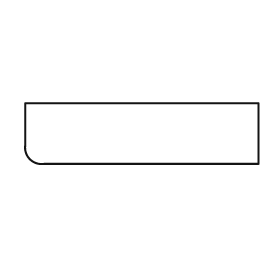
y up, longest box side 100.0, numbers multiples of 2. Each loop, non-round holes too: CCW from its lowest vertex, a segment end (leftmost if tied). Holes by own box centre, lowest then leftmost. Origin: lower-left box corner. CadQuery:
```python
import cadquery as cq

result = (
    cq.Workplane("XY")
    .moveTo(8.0, 0.0)
    .lineTo(100.0, 0.0)
    .lineTo(100.0, 26.0)
    .lineTo(0.0, 26.0)
    .lineTo(0.0, 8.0)
    .threePointArc((2.0, 2.0), (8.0, 0.0))
    .close()
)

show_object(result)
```